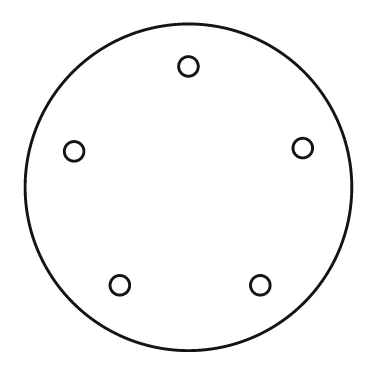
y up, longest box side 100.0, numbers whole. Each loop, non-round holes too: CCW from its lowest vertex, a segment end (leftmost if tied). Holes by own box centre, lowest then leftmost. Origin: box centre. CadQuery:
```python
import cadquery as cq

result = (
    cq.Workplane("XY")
    .moveTo(0.0, 0.0)
    .circle(50.0)
    .moveTo(-21.0, -30.0)
    .circle(3.0)
    .moveTo(22.0, -30.0)
    .circle(3.0)
    .moveTo(-35.0, 11.0)
    .circle(3.0)
    .moveTo(35.0, 12.0)
    .circle(3.0)
    .moveTo(0.0, 37.0)
    .circle(3.0)
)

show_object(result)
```